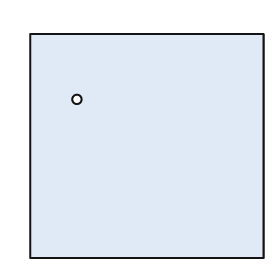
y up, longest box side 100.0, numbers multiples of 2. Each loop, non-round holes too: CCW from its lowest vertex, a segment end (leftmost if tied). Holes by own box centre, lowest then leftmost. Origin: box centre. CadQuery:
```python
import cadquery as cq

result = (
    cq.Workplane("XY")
    .moveTo(-50.0, -48.0)
    .lineTo(50.0, -48.0)
    .lineTo(50.0, 48.0)
    .lineTo(-50.0, 48.0)
    .close()
    .moveTo(-30.0, 20.0)
    .circle(2.0)
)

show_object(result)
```